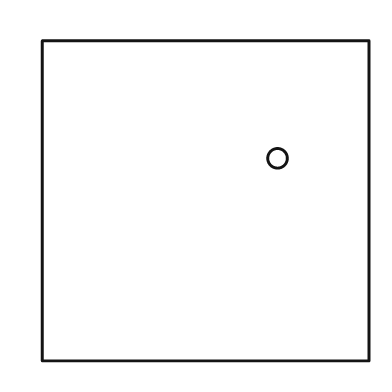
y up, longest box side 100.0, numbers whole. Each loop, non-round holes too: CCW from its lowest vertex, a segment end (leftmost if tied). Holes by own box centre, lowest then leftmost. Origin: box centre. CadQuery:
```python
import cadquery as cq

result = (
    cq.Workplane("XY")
    .moveTo(-50.0, -49.0)
    .lineTo(50.0, -49.0)
    .lineTo(50.0, 49.0)
    .lineTo(-50.0, 49.0)
    .close()
    .moveTo(22.0, 13.0)
    .circle(3.0)
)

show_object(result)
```